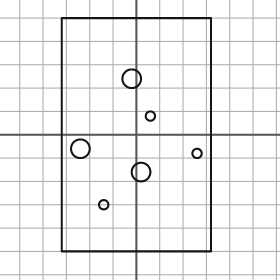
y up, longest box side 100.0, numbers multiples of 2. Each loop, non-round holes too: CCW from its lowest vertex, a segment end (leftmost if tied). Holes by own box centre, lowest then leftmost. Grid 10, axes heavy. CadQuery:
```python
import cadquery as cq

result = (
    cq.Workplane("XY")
    .moveTo(-32.0, -50.0)
    .lineTo(32.0, -50.0)
    .lineTo(32.0, 50.0)
    .lineTo(-32.0, 50.0)
    .close()
    .moveTo(-14.0, -30.0)
    .circle(2.0)
    .moveTo(2.0, -16.0)
    .circle(4.0)
    .moveTo(26.0, -8.0)
    .circle(2.0)
    .moveTo(-24.0, -6.0)
    .circle(4.0)
    .moveTo(6.0, 8.0)
    .circle(2.0)
    .moveTo(-2.0, 24.0)
    .circle(4.0)
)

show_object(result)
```